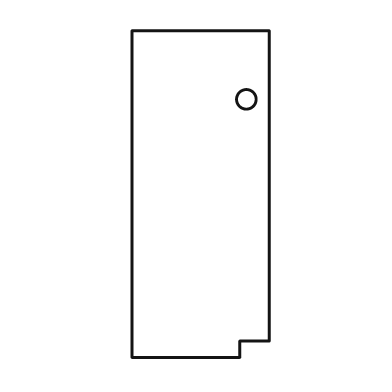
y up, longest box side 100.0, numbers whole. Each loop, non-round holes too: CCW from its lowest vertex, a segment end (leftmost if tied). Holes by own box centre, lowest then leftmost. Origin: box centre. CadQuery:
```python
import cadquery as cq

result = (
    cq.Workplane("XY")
    .moveTo(-21.0, -50.0)
    .lineTo(12.0, -50.0)
    .lineTo(12.0, -45.0)
    .lineTo(21.0, -45.0)
    .lineTo(21.0, 50.0)
    .lineTo(-21.0, 50.0)
    .close()
    .moveTo(14.0, 29.0)
    .circle(3.0)
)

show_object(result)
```